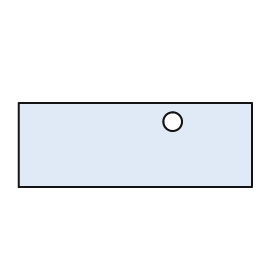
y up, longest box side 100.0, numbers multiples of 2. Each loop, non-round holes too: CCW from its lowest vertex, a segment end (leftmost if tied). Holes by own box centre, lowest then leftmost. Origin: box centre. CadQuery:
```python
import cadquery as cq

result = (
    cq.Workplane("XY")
    .moveTo(-50.0, -18.0)
    .lineTo(50.0, -18.0)
    .lineTo(50.0, 18.0)
    .lineTo(-50.0, 18.0)
    .close()
    .moveTo(16.0, 10.0)
    .circle(4.0)
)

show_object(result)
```